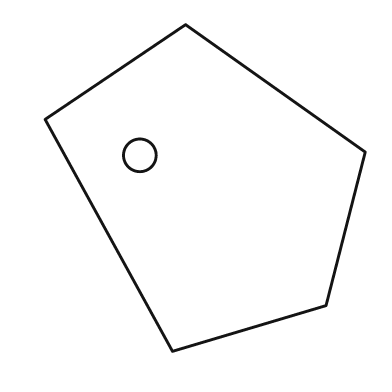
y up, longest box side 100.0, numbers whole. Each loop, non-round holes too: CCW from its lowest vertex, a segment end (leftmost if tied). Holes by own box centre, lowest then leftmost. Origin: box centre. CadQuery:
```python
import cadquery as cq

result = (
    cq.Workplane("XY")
    .moveTo(-10.0, -50.0)
    .lineTo(37.0, -36.0)
    .lineTo(49.0, 11.0)
    .lineTo(-6.0, 50.0)
    .lineTo(-49.0, 21.0)
    .close()
    .moveTo(-20.0, 10.0)
    .circle(5.0)
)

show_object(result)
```